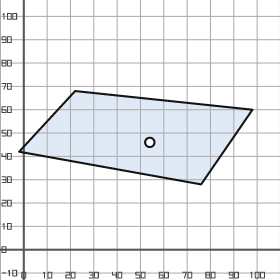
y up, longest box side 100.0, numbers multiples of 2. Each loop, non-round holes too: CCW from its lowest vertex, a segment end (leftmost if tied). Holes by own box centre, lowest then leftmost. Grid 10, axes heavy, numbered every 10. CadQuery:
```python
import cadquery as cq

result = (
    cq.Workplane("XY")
    .moveTo(76.0, 28.0)
    .lineTo(98.0, 60.0)
    .lineTo(22.0, 68.0)
    .lineTo(-2.0, 42.0)
    .close()
    .moveTo(54.0, 46.0)
    .circle(2.0)
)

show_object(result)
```